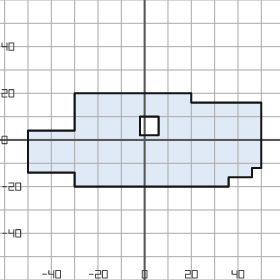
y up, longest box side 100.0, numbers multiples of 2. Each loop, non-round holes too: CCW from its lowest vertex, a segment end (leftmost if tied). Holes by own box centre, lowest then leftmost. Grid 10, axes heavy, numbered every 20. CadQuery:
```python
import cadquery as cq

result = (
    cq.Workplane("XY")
    .moveTo(-30.0, -20.0)
    .lineTo(36.0, -20.0)
    .lineTo(36.0, -16.0)
    .lineTo(46.0, -16.0)
    .lineTo(46.0, -12.0)
    .lineTo(50.0, -12.0)
    .lineTo(50.0, 16.0)
    .lineTo(20.0, 16.0)
    .lineTo(20.0, 20.0)
    .lineTo(-30.0, 20.0)
    .lineTo(-30.0, 4.0)
    .lineTo(-50.0, 4.0)
    .lineTo(-50.0, -14.0)
    .lineTo(-30.0, -14.0)
    .close()
    .moveTo(-2.0, 2.0)
    .lineTo(6.0, 2.0)
    .lineTo(6.0, 10.0)
    .lineTo(-2.0, 10.0)
    .close()
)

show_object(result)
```